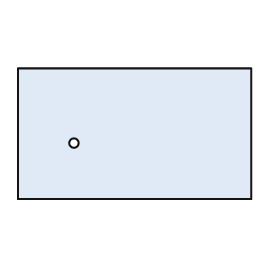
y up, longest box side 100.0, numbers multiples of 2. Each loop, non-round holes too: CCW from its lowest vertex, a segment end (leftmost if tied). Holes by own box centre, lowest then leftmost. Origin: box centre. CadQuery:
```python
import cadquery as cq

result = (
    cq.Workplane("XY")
    .moveTo(-50.0, -28.0)
    .lineTo(50.0, -28.0)
    .lineTo(50.0, 28.0)
    .lineTo(-50.0, 28.0)
    .close()
    .moveTo(-26.0, -4.0)
    .circle(2.0)
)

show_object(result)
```